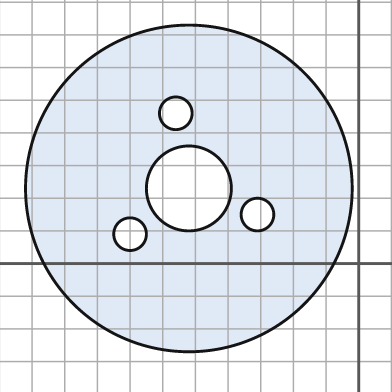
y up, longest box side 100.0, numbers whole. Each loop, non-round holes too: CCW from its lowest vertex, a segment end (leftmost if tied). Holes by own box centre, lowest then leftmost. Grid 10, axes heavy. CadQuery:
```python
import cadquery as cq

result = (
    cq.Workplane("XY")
    .moveTo(-52.0, 23.0)
    .circle(50.0)
    .moveTo(-70.0, 9.0)
    .circle(5.0)
    .moveTo(-31.0, 15.0)
    .circle(5.0)
    .moveTo(-52.0, 23.0)
    .circle(13.0)
    .moveTo(-56.0, 46.0)
    .circle(5.0)
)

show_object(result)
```